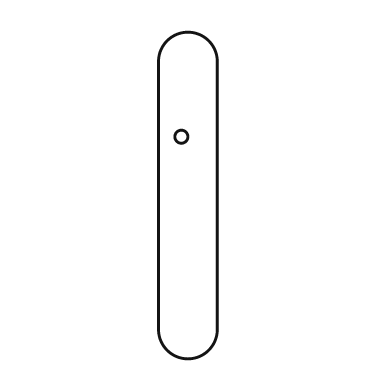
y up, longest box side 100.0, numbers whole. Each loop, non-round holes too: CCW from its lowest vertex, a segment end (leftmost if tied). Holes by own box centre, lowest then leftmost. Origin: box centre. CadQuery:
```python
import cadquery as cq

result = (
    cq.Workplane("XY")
    .moveTo(-9.0, -41.0)
    .threePointArc((0.0, -50.0), (9.0, -41.0))
    .lineTo(9.0, 41.0)
    .threePointArc((0.0, 50.0), (-9.0, 41.0))
    .close()
    .moveTo(-2.0, 18.0)
    .circle(2.0)
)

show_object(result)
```